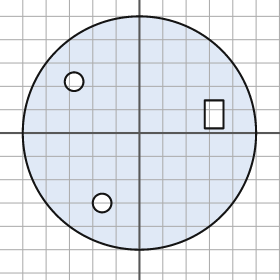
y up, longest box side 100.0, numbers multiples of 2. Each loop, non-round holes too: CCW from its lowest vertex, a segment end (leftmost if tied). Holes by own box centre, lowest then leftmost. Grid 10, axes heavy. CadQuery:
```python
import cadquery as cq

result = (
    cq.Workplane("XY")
    .moveTo(0.0, 0.0)
    .circle(50.0)
    .moveTo(-16.0, -30.0)
    .circle(4.0)
    .moveTo(28.0, 2.0)
    .lineTo(36.0, 2.0)
    .lineTo(36.0, 14.0)
    .lineTo(28.0, 14.0)
    .close()
    .moveTo(-28.0, 22.0)
    .circle(4.0)
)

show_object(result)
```